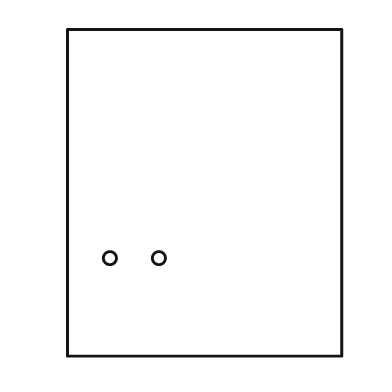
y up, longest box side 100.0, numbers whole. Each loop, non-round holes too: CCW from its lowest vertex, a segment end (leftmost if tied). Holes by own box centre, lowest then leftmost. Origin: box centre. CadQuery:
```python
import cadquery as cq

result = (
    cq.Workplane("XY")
    .moveTo(-42.0, -50.0)
    .lineTo(42.0, -50.0)
    .lineTo(42.0, 50.0)
    .lineTo(-42.0, 50.0)
    .close()
    .moveTo(-29.0, -20.0)
    .circle(2.0)
    .moveTo(-14.0, -20.0)
    .circle(2.0)
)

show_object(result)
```